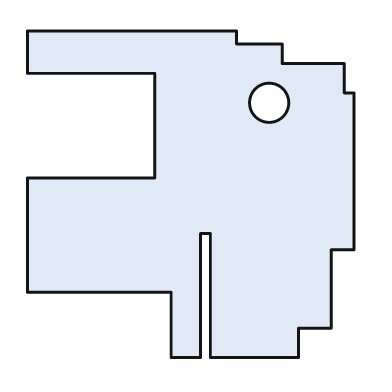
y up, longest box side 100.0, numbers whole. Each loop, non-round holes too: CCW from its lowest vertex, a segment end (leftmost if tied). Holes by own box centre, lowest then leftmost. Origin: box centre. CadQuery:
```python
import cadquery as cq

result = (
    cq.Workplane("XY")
    .moveTo(-6.0, -50.0)
    .lineTo(3.0, -50.0)
    .lineTo(3.0, -12.0)
    .lineTo(6.0, -12.0)
    .lineTo(6.0, -50.0)
    .lineTo(33.0, -50.0)
    .lineTo(33.0, -41.0)
    .lineTo(43.0, -41.0)
    .lineTo(43.0, -17.0)
    .lineTo(50.0, -17.0)
    .lineTo(50.0, 31.0)
    .lineTo(47.0, 31.0)
    .lineTo(47.0, 40.0)
    .lineTo(28.0, 40.0)
    .lineTo(28.0, 46.0)
    .lineTo(14.0, 46.0)
    .lineTo(14.0, 50.0)
    .lineTo(-50.0, 50.0)
    .lineTo(-50.0, 37.0)
    .lineTo(-11.0, 37.0)
    .lineTo(-11.0, 5.0)
    .lineTo(-50.0, 5.0)
    .lineTo(-50.0, -30.0)
    .lineTo(-6.0, -30.0)
    .close()
    .moveTo(24.0, 28.0)
    .circle(6.0)
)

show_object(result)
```